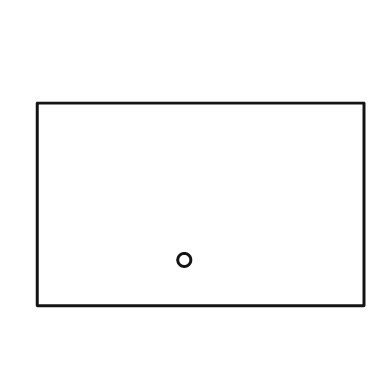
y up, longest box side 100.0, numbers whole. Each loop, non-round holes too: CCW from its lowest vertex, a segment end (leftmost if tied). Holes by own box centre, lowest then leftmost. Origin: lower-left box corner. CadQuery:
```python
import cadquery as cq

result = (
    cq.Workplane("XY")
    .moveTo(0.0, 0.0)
    .lineTo(100.0, 0.0)
    .lineTo(100.0, 62.0)
    .lineTo(0.0, 62.0)
    .close()
    .moveTo(45.0, 14.0)
    .circle(2.0)
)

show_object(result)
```